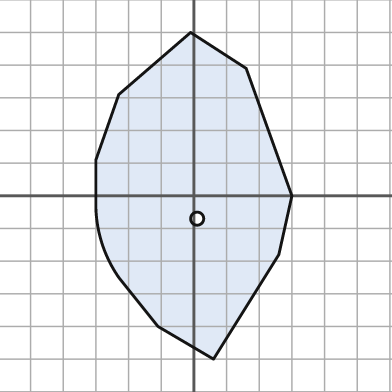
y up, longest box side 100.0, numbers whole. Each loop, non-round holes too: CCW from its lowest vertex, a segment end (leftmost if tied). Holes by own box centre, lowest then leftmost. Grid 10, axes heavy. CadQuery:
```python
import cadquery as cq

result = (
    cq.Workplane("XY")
    .moveTo(6.0, -50.0)
    .lineTo(26.0, -18.0)
    .lineTo(30.0, 0.0)
    .lineTo(16.0, 39.0)
    .lineTo(-1.0, 50.0)
    .lineTo(-23.0, 31.0)
    .lineTo(-30.0, 11.0)
    .lineTo(-30.0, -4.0)
    .threePointArc((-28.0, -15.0), (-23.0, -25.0))
    .lineTo(-11.0, -40.0)
    .close()
    .moveTo(1.0, -7.0)
    .circle(2.0)
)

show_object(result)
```